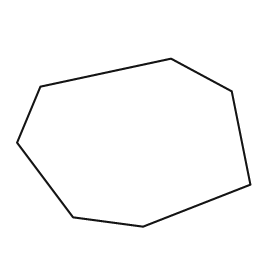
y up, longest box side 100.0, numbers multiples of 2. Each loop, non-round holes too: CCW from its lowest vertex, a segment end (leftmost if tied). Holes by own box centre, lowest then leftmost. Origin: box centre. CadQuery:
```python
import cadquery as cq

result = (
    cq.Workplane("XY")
    .moveTo(4.0, -36.0)
    .lineTo(50.0, -18.0)
    .lineTo(42.0, 22.0)
    .lineTo(16.0, 36.0)
    .lineTo(-40.0, 24.0)
    .lineTo(-50.0, 0.0)
    .lineTo(-26.0, -32.0)
    .close()
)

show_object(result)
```